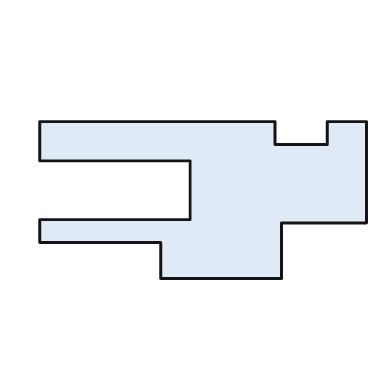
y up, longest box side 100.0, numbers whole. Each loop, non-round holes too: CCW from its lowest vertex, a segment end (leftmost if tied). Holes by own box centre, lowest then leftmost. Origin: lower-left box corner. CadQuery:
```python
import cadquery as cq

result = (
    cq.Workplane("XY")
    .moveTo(37.0, 0.0)
    .lineTo(74.0, 0.0)
    .lineTo(74.0, 17.0)
    .lineTo(100.0, 17.0)
    .lineTo(100.0, 48.0)
    .lineTo(88.0, 48.0)
    .lineTo(88.0, 41.0)
    .lineTo(72.0, 41.0)
    .lineTo(72.0, 48.0)
    .lineTo(0.0, 48.0)
    .lineTo(0.0, 36.0)
    .lineTo(46.0, 36.0)
    .lineTo(46.0, 18.0)
    .lineTo(0.0, 18.0)
    .lineTo(0.0, 11.0)
    .lineTo(37.0, 11.0)
    .close()
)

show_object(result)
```